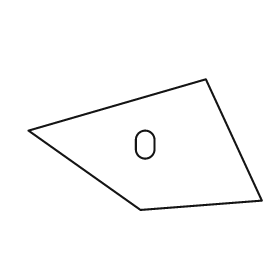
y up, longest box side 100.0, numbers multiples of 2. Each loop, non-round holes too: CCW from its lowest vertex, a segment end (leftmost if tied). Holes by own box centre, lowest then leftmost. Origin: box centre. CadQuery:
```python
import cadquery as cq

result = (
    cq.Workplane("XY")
    .moveTo(-2.0, -28.0)
    .lineTo(50.0, -24.0)
    .lineTo(26.0, 28.0)
    .lineTo(-50.0, 6.0)
    .close()
    .moveTo(-4.0, -2.0)
    .threePointArc((0.0, -6.0), (4.0, -2.0))
    .lineTo(4.0, 2.0)
    .threePointArc((0.0, 6.0), (-4.0, 2.0))
    .close()
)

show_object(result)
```